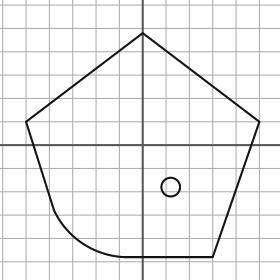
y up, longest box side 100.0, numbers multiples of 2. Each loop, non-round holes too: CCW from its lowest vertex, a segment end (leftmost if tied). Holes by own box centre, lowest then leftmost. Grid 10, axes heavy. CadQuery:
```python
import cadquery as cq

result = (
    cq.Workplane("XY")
    .moveTo(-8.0, -48.0)
    .lineTo(30.0, -48.0)
    .lineTo(50.0, 10.0)
    .lineTo(0.0, 48.0)
    .lineTo(-50.0, 10.0)
    .lineTo(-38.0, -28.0)
    .threePointArc((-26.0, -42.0), (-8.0, -48.0))
    .close()
    .moveTo(12.0, -18.0)
    .circle(4.0)
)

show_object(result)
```